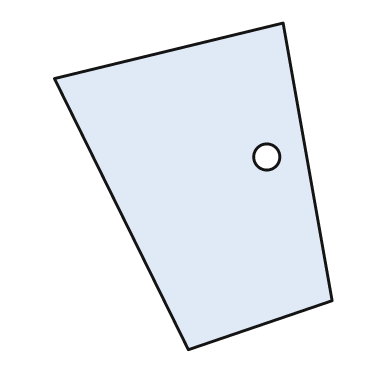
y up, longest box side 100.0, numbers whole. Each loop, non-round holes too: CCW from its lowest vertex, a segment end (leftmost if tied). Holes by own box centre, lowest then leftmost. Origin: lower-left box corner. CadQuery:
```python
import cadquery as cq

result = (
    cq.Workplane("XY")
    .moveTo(41.0, 0.0)
    .lineTo(85.0, 15.0)
    .lineTo(70.0, 100.0)
    .lineTo(0.0, 83.0)
    .close()
    .moveTo(65.0, 59.0)
    .circle(4.0)
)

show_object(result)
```